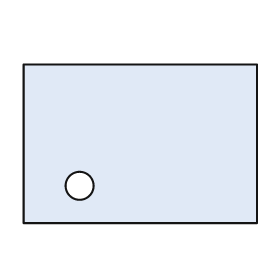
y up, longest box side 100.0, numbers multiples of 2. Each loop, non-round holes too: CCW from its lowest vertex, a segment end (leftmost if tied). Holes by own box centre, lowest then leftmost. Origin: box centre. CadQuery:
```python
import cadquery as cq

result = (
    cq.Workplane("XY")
    .moveTo(-50.0, -34.0)
    .lineTo(50.0, -34.0)
    .lineTo(50.0, 34.0)
    .lineTo(-50.0, 34.0)
    .close()
    .moveTo(-26.0, -18.0)
    .circle(6.0)
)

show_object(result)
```